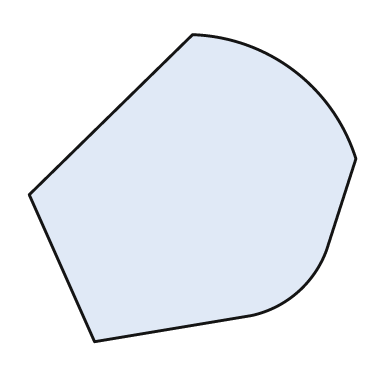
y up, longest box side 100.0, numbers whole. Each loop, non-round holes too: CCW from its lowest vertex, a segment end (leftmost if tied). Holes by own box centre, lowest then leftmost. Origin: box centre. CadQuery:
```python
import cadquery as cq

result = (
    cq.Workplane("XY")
    .moveTo(-30.0, -47.0)
    .lineTo(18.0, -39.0)
    .threePointArc((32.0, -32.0), (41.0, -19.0))
    .lineTo(50.0, 9.0)
    .threePointArc((31.0, 36.0), (0.0, 47.0))
    .lineTo(-50.0, -2.0)
    .close()
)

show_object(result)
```